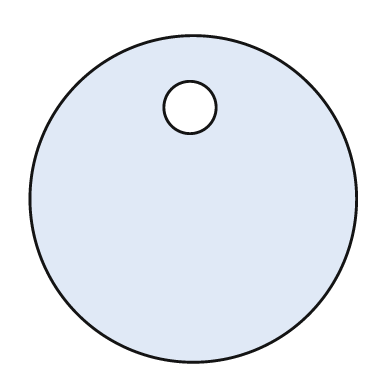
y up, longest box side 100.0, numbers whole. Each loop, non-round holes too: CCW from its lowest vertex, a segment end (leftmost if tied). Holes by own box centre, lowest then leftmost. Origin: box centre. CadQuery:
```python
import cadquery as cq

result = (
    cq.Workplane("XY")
    .moveTo(0.0, 0.0)
    .circle(50.0)
    .moveTo(-1.0, 28.0)
    .circle(8.0)
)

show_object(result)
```